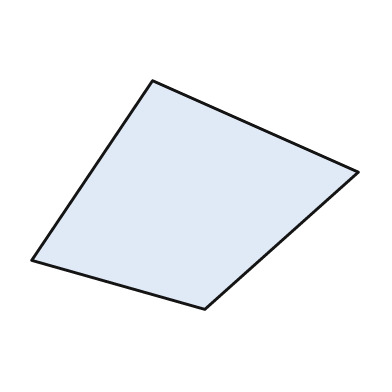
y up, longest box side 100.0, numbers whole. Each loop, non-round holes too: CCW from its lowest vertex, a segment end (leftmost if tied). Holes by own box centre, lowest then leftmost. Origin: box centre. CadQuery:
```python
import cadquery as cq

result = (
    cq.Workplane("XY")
    .moveTo(3.0, -35.0)
    .lineTo(50.0, 7.0)
    .lineTo(-13.0, 35.0)
    .lineTo(-50.0, -20.0)
    .close()
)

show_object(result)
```